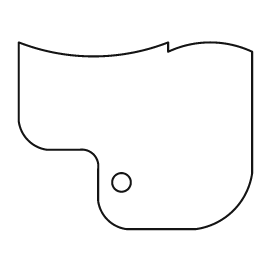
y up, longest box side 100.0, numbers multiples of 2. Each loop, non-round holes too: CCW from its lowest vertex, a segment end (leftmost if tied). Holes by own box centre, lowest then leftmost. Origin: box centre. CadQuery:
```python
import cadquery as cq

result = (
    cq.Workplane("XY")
    .moveTo(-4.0, -40.0)
    .lineTo(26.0, -40.0)
    .threePointArc((42.0, -32.0), (50.0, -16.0))
    .lineTo(50.0, 36.0)
    .threePointArc((32.0, 40.0), (14.0, 36.0))
    .lineTo(14.0, 40.0)
    .threePointArc((-18.0, 34.0), (-50.0, 40.0))
    .lineTo(-50.0, 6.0)
    .threePointArc((-46.0, -2.0), (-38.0, -6.0))
    .lineTo(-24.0, -6.0)
    .threePointArc((-18.0, -8.0), (-16.0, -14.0))
    .lineTo(-16.0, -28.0)
    .threePointArc((-12.0, -36.0), (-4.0, -40.0))
    .close()
    .moveTo(-6.0, -20.0)
    .circle(4.0)
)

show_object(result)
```